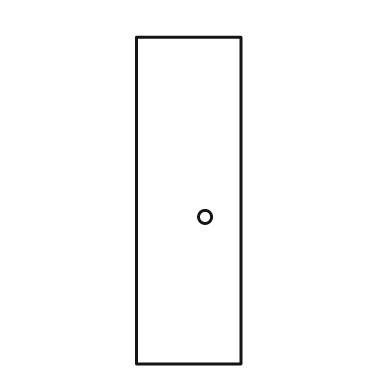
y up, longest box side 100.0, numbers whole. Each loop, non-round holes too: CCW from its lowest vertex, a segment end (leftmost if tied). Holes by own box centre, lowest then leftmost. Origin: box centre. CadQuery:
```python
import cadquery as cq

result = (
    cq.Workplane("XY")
    .moveTo(-16.0, -50.0)
    .lineTo(16.0, -50.0)
    .lineTo(16.0, 50.0)
    .lineTo(-16.0, 50.0)
    .close()
    .moveTo(5.0, -5.0)
    .circle(2.0)
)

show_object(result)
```